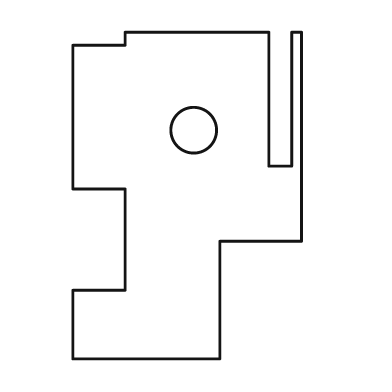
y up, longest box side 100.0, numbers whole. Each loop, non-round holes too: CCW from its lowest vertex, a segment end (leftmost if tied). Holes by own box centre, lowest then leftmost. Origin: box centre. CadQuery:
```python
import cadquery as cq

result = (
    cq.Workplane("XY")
    .moveTo(-35.0, -50.0)
    .lineTo(10.0, -50.0)
    .lineTo(10.0, -14.0)
    .lineTo(35.0, -14.0)
    .lineTo(35.0, 50.0)
    .lineTo(32.0, 50.0)
    .lineTo(32.0, 9.0)
    .lineTo(25.0, 9.0)
    .lineTo(25.0, 50.0)
    .lineTo(-19.0, 50.0)
    .lineTo(-19.0, 46.0)
    .lineTo(-35.0, 46.0)
    .lineTo(-35.0, 2.0)
    .lineTo(-19.0, 2.0)
    .lineTo(-19.0, -29.0)
    .lineTo(-35.0, -29.0)
    .close()
    .moveTo(2.0, 20.0)
    .circle(7.0)
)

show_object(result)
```